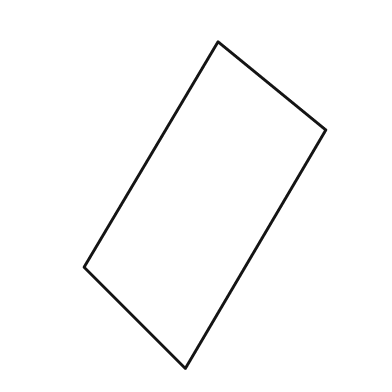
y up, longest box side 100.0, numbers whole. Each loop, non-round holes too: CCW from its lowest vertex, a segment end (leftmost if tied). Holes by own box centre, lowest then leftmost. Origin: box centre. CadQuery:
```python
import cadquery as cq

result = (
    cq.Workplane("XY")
    .moveTo(-6.0, -50.0)
    .lineTo(37.0, 23.0)
    .lineTo(4.0, 50.0)
    .lineTo(-37.0, -19.0)
    .close()
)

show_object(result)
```